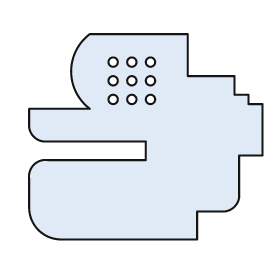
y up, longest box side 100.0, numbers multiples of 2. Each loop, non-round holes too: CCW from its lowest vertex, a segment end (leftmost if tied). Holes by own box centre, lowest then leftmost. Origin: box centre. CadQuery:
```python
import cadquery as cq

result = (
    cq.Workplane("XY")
    .moveTo(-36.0, -44.0)
    .lineTo(22.0, -44.0)
    .lineTo(22.0, -32.0)
    .lineTo(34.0, -32.0)
    .threePointArc((38.0, -30.0), (40.0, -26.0))
    .lineTo(40.0, -8.0)
    .lineTo(50.0, -8.0)
    .lineTo(50.0, 14.0)
    .lineTo(44.0, 14.0)
    .lineTo(44.0, 18.0)
    .lineTo(38.0, 18.0)
    .lineTo(38.0, 26.0)
    .lineTo(18.0, 26.0)
    .lineTo(18.0, 44.0)
    .lineTo(-24.0, 44.0)
    .threePointArc((-32.0, 28.0), (-24.0, 12.0))
    .lineTo(-50.0, 12.0)
    .lineTo(-50.0, 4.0)
    .threePointArc((-48.0, 0.0), (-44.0, -2.0))
    .lineTo(0.0, -2.0)
    .lineTo(0.0, -10.0)
    .lineTo(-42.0, -10.0)
    .threePointArc((-48.0, -12.0), (-50.0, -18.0))
    .lineTo(-50.0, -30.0)
    .threePointArc((-46.0, -40.0), (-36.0, -44.0))
    .close()
    .moveTo(-14.0, 16.0)
    .circle(2.0)
    .moveTo(-6.0, 16.0)
    .circle(2.0)
    .moveTo(2.0, 16.0)
    .circle(2.0)
    .moveTo(-14.0, 24.0)
    .circle(2.0)
    .moveTo(-6.0, 24.0)
    .circle(2.0)
    .moveTo(2.0, 24.0)
    .circle(2.0)
    .moveTo(-14.0, 32.0)
    .circle(2.0)
    .moveTo(-6.0, 32.0)
    .circle(2.0)
    .moveTo(2.0, 32.0)
    .circle(2.0)
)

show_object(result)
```